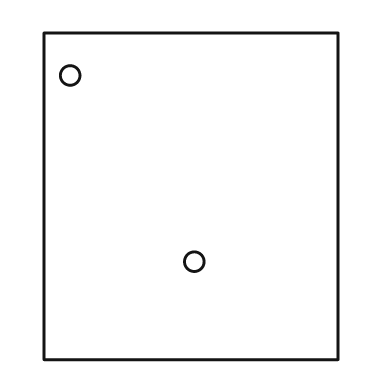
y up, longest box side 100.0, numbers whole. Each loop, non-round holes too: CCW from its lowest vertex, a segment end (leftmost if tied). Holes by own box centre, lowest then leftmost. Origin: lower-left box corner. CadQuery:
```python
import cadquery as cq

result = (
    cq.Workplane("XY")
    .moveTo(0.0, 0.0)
    .lineTo(90.0, 0.0)
    .lineTo(90.0, 100.0)
    .lineTo(0.0, 100.0)
    .close()
    .moveTo(46.0, 30.0)
    .circle(3.0)
    .moveTo(8.0, 87.0)
    .circle(3.0)
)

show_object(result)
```